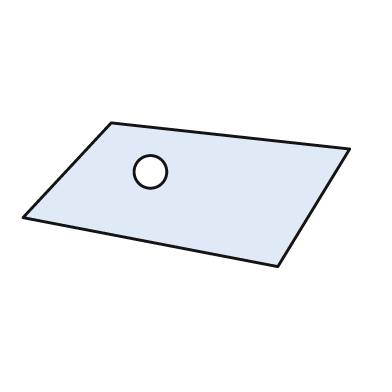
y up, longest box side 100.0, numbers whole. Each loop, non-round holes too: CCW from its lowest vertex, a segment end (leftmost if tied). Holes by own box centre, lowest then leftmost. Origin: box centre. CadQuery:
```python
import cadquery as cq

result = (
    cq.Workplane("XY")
    .moveTo(28.0, -22.0)
    .lineTo(50.0, 14.0)
    .lineTo(-23.0, 22.0)
    .lineTo(-50.0, -7.0)
    .close()
    .moveTo(-11.0, 7.0)
    .circle(5.0)
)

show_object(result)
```